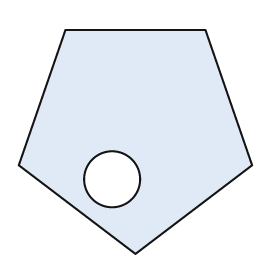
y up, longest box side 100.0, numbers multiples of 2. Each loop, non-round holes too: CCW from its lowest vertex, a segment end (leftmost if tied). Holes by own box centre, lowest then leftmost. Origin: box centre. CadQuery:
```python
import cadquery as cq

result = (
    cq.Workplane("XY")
    .moveTo(0.0, -48.0)
    .lineTo(50.0, -10.0)
    .lineTo(30.0, 48.0)
    .lineTo(-30.0, 48.0)
    .lineTo(-50.0, -10.0)
    .close()
    .moveTo(-10.0, -16.0)
    .circle(12.0)
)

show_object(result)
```